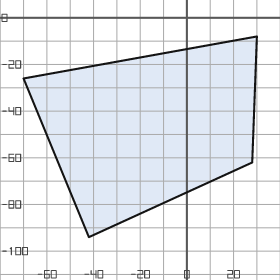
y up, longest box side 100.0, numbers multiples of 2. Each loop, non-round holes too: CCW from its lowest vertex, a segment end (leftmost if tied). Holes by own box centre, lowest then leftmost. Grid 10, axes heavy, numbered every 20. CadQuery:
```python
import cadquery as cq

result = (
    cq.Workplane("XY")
    .moveTo(-42.0, -94.0)
    .lineTo(28.0, -62.0)
    .lineTo(30.0, -8.0)
    .lineTo(-70.0, -26.0)
    .close()
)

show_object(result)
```